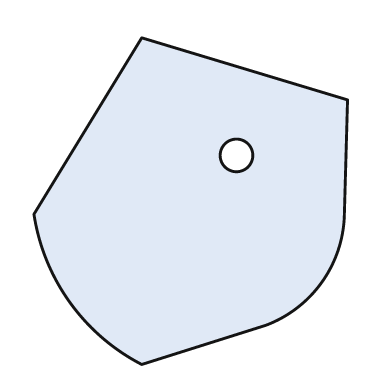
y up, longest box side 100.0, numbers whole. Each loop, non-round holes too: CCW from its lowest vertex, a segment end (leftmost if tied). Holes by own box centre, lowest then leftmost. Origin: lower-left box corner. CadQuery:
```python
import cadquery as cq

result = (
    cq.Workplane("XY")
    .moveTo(33.0, 0.0)
    .lineTo(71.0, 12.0)
    .threePointArc((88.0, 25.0), (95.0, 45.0))
    .lineTo(96.0, 81.0)
    .lineTo(33.0, 100.0)
    .lineTo(0.0, 46.0)
    .threePointArc((11.0, 19.0), (33.0, 0.0))
    .close()
    .moveTo(62.0, 64.0)
    .circle(5.0)
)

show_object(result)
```